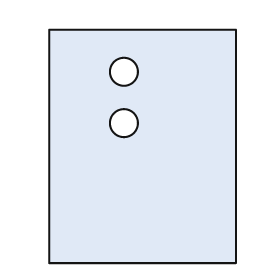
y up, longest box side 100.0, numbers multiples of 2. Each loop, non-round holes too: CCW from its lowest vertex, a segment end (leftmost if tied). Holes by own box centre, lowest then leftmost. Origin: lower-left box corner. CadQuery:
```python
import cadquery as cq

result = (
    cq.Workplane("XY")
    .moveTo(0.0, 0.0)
    .lineTo(80.0, 0.0)
    .lineTo(80.0, 100.0)
    .lineTo(0.0, 100.0)
    .close()
    .moveTo(32.0, 60.0)
    .circle(6.0)
    .moveTo(32.0, 82.0)
    .circle(6.0)
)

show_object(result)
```